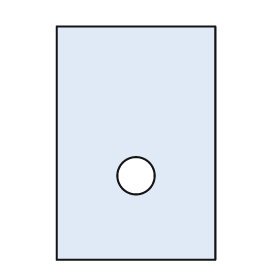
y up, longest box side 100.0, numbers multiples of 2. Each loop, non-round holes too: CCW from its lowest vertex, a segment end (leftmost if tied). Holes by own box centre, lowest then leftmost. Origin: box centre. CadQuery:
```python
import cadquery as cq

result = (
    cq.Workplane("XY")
    .moveTo(-34.0, -50.0)
    .lineTo(34.0, -50.0)
    .lineTo(34.0, 50.0)
    .lineTo(-34.0, 50.0)
    .close()
    .moveTo(0.0, -14.0)
    .circle(8.0)
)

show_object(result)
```